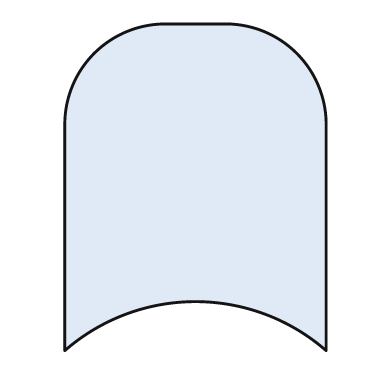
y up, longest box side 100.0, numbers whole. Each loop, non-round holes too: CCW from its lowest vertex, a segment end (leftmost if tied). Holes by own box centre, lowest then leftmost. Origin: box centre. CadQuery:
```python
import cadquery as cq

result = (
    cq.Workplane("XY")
    .moveTo(-40.0, -50.0)
    .threePointArc((0.0, -35.0), (40.0, -50.0))
    .lineTo(40.0, 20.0)
    .threePointArc((31.0, 41.0), (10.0, 50.0))
    .lineTo(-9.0, 50.0)
    .threePointArc((-31.0, 41.0), (-40.0, 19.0))
    .close()
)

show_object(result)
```